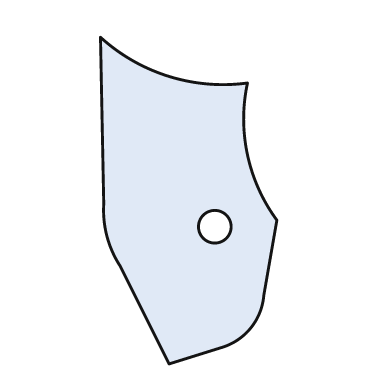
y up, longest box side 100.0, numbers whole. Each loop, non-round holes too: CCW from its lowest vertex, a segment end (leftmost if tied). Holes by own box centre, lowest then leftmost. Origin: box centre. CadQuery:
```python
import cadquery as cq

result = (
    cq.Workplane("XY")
    .moveTo(-6.0, -50.0)
    .lineTo(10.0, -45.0)
    .threePointArc((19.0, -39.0), (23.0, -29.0))
    .lineTo(27.0, -6.0)
    .threePointArc((18.0, 14.0), (18.0, 36.0))
    .threePointArc((-6.0, 38.0), (-27.0, 50.0))
    .lineTo(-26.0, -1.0)
    .threePointArc((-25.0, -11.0), (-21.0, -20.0))
    .close()
    .moveTo(8.0, -8.0)
    .circle(5.0)
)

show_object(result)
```